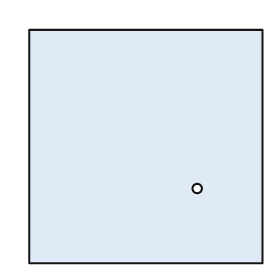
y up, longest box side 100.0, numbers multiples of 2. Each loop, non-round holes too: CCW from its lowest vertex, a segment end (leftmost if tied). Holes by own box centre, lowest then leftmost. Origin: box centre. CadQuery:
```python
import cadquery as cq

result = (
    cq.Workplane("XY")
    .moveTo(-50.0, -50.0)
    .lineTo(50.0, -50.0)
    .lineTo(50.0, 50.0)
    .lineTo(-50.0, 50.0)
    .close()
    .moveTo(22.0, -18.0)
    .circle(2.0)
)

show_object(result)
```